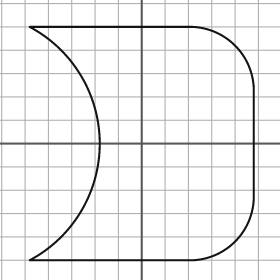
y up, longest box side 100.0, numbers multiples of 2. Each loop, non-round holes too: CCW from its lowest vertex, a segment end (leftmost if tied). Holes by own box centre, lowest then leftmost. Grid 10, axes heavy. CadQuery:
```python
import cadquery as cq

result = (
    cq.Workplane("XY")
    .moveTo(-48.0, -50.0)
    .lineTo(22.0, -50.0)
    .threePointArc((40.0, -42.0), (48.0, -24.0))
    .lineTo(48.0, 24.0)
    .threePointArc((40.0, 42.0), (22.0, 50.0))
    .lineTo(-48.0, 50.0)
    .threePointArc((-18.0, 0.0), (-48.0, -50.0))
    .close()
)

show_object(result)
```